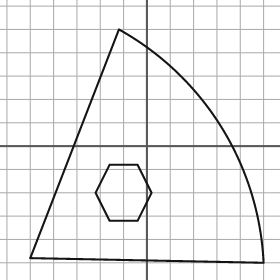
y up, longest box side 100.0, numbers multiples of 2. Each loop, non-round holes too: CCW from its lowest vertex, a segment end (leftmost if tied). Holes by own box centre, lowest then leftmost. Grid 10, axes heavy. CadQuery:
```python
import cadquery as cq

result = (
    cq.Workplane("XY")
    .moveTo(50.0, -50.0)
    .threePointArc((32.0, 8.0), (-12.0, 50.0))
    .lineTo(-50.0, -48.0)
    .close()
    .moveTo(-16.0, -32.0)
    .lineTo(-4.0, -32.0)
    .lineTo(2.0, -20.0)
    .lineTo(-4.0, -8.0)
    .lineTo(-16.0, -8.0)
    .lineTo(-22.0, -20.0)
    .close()
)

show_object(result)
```